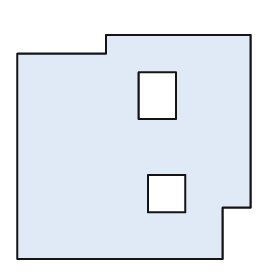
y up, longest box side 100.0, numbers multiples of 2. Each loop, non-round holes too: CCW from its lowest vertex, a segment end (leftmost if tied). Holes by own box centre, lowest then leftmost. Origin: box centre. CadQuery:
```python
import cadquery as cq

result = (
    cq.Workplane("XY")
    .moveTo(-50.0, -48.0)
    .lineTo(38.0, -48.0)
    .lineTo(38.0, -26.0)
    .lineTo(50.0, -26.0)
    .lineTo(50.0, 48.0)
    .lineTo(-12.0, 48.0)
    .lineTo(-12.0, 40.0)
    .lineTo(-50.0, 40.0)
    .close()
    .moveTo(6.0, -28.0)
    .lineTo(22.0, -28.0)
    .lineTo(22.0, -12.0)
    .lineTo(6.0, -12.0)
    .close()
    .moveTo(2.0, 12.0)
    .lineTo(18.0, 12.0)
    .lineTo(18.0, 32.0)
    .lineTo(2.0, 32.0)
    .close()
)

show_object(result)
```